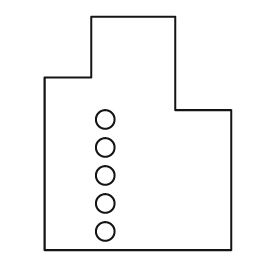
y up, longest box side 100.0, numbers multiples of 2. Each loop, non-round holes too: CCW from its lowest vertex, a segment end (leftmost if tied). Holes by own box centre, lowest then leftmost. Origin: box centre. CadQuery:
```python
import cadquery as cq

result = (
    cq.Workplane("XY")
    .moveTo(-40.0, -50.0)
    .lineTo(40.0, -50.0)
    .lineTo(40.0, 10.0)
    .lineTo(16.0, 10.0)
    .lineTo(16.0, 50.0)
    .lineTo(-20.0, 50.0)
    .lineTo(-20.0, 24.0)
    .lineTo(-40.0, 24.0)
    .close()
    .moveTo(-14.0, -42.0)
    .circle(4.0)
    .moveTo(-14.0, -30.0)
    .circle(4.0)
    .moveTo(-14.0, -18.0)
    .circle(4.0)
    .moveTo(-14.0, -6.0)
    .circle(4.0)
    .moveTo(-14.0, 6.0)
    .circle(4.0)
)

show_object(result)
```